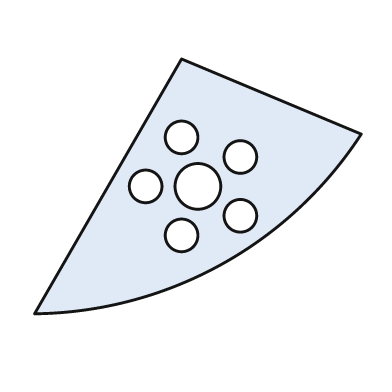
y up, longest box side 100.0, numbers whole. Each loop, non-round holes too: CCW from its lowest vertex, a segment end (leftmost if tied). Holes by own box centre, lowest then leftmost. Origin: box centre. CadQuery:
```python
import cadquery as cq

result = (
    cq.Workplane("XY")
    .moveTo(-50.0, -39.0)
    .threePointArc((7.0, -24.0), (50.0, 16.0))
    .lineTo(-5.0, 39.0)
    .close()
    .moveTo(-5.0, -15.0)
    .circle(5.0)
    .moveTo(13.0, -9.0)
    .circle(5.0)
    .moveTo(-16.0, 0.0)
    .circle(5.0)
    .moveTo(0.0, 0.0)
    .circle(7.0)
    .moveTo(13.0, 9.0)
    .circle(5.0)
    .moveTo(-5.0, 15.0)
    .circle(5.0)
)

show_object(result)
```